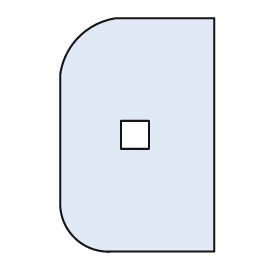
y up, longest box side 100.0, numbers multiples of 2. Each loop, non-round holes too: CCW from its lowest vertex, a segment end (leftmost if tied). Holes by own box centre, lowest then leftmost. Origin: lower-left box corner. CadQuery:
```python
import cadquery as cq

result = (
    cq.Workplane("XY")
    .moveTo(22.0, 0.0)
    .lineTo(66.0, 0.0)
    .lineTo(66.0, 100.0)
    .lineTo(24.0, 100.0)
    .threePointArc((8.0, 92.0), (0.0, 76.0))
    .lineTo(0.0, 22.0)
    .threePointArc((6.0, 6.0), (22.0, 0.0))
    .close()
    .moveTo(26.0, 44.0)
    .lineTo(38.0, 44.0)
    .lineTo(38.0, 56.0)
    .lineTo(26.0, 56.0)
    .close()
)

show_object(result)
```